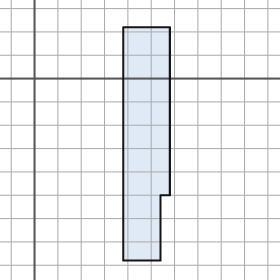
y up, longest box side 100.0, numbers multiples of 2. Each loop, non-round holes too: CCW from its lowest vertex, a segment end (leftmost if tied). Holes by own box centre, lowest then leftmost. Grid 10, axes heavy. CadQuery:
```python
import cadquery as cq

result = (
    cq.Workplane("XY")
    .moveTo(38.0, -78.0)
    .lineTo(54.0, -78.0)
    .lineTo(54.0, -50.0)
    .lineTo(58.0, -50.0)
    .lineTo(58.0, 22.0)
    .lineTo(38.0, 22.0)
    .close()
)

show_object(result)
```